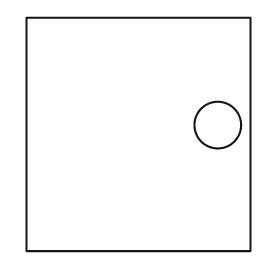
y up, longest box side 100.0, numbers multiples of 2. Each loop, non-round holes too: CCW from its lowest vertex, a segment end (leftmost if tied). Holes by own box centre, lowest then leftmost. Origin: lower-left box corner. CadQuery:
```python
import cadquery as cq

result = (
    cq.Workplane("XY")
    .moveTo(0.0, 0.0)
    .lineTo(96.0, 0.0)
    .lineTo(96.0, 100.0)
    .lineTo(0.0, 100.0)
    .close()
    .moveTo(82.0, 54.0)
    .circle(10.0)
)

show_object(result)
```